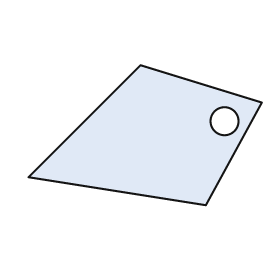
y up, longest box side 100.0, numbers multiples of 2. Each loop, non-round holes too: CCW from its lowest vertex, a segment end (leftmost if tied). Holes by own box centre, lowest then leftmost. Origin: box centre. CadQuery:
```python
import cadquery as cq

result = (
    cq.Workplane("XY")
    .moveTo(26.0, -30.0)
    .lineTo(50.0, 14.0)
    .lineTo(-2.0, 30.0)
    .lineTo(-50.0, -18.0)
    .close()
    .moveTo(34.0, 6.0)
    .circle(6.0)
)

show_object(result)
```